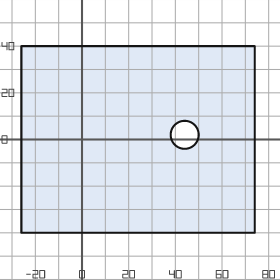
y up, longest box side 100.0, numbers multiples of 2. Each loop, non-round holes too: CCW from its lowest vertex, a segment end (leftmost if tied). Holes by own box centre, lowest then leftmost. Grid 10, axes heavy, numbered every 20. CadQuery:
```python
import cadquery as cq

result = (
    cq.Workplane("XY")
    .moveTo(-26.0, -40.0)
    .lineTo(74.0, -40.0)
    .lineTo(74.0, 40.0)
    .lineTo(-26.0, 40.0)
    .close()
    .moveTo(44.0, 2.0)
    .circle(6.0)
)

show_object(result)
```